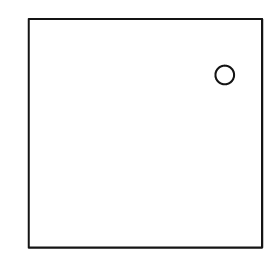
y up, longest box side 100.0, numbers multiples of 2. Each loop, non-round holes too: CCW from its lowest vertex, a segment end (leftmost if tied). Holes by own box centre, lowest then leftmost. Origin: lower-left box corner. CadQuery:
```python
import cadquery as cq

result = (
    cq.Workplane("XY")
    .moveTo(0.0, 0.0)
    .lineTo(100.0, 0.0)
    .lineTo(100.0, 98.0)
    .lineTo(0.0, 98.0)
    .close()
    .moveTo(84.0, 74.0)
    .circle(4.0)
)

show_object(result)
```